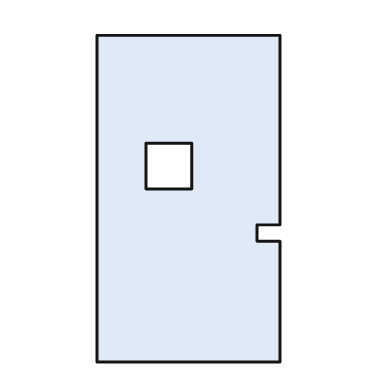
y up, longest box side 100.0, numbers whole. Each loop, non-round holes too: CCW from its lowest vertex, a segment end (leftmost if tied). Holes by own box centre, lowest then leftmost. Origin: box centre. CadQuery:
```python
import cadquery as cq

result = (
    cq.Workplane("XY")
    .moveTo(-28.0, -50.0)
    .lineTo(28.0, -50.0)
    .lineTo(28.0, -13.0)
    .lineTo(21.0, -13.0)
    .lineTo(21.0, -8.0)
    .lineTo(28.0, -8.0)
    .lineTo(28.0, 50.0)
    .lineTo(-28.0, 50.0)
    .close()
    .moveTo(-13.0, 3.0)
    .lineTo(1.0, 3.0)
    .lineTo(1.0, 17.0)
    .lineTo(-13.0, 17.0)
    .close()
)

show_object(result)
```